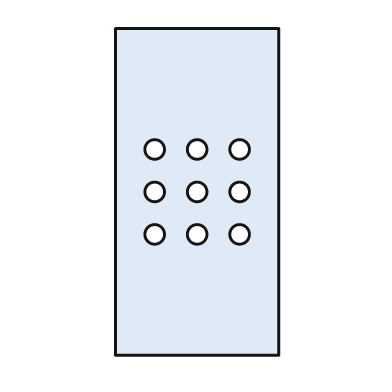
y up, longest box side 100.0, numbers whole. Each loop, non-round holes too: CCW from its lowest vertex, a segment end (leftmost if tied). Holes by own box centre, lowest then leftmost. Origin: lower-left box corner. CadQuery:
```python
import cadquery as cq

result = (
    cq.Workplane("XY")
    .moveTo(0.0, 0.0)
    .lineTo(50.0, 0.0)
    .lineTo(50.0, 100.0)
    .lineTo(0.0, 100.0)
    .close()
    .moveTo(12.0, 37.0)
    .circle(3.0)
    .moveTo(25.0, 37.0)
    .circle(3.0)
    .moveTo(38.0, 37.0)
    .circle(3.0)
    .moveTo(12.0, 50.0)
    .circle(3.0)
    .moveTo(25.0, 50.0)
    .circle(3.0)
    .moveTo(38.0, 50.0)
    .circle(3.0)
    .moveTo(12.0, 63.0)
    .circle(3.0)
    .moveTo(25.0, 63.0)
    .circle(3.0)
    .moveTo(38.0, 63.0)
    .circle(3.0)
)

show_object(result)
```